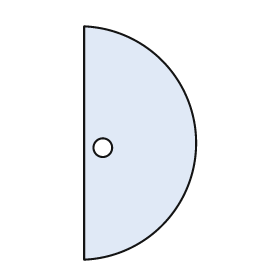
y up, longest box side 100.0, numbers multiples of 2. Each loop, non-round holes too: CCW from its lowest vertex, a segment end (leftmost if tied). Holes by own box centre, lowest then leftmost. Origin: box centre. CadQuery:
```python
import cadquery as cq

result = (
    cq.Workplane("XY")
    .moveTo(-24.0, -50.0)
    .threePointArc((24.0, 0.0), (-24.0, 50.0))
    .close()
    .moveTo(-16.0, -2.0)
    .circle(4.0)
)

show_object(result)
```